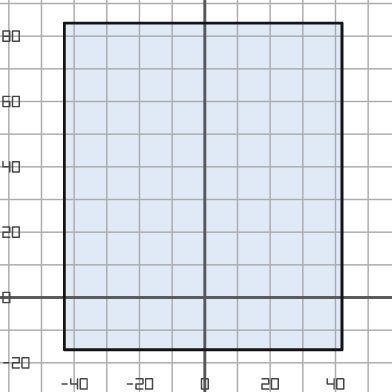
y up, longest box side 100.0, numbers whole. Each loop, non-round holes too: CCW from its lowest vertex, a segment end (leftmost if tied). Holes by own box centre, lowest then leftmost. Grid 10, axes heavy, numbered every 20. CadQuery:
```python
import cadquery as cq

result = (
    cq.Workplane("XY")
    .moveTo(-43.0, -16.0)
    .lineTo(42.0, -16.0)
    .lineTo(42.0, 84.0)
    .lineTo(-43.0, 84.0)
    .close()
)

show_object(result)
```